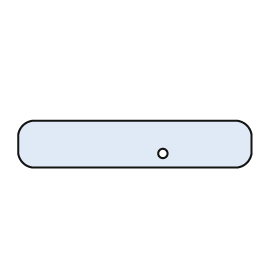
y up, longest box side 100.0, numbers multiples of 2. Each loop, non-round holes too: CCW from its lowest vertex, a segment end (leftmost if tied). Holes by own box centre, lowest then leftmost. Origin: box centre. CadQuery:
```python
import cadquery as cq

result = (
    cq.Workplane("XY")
    .moveTo(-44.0, -10.0)
    .lineTo(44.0, -10.0)
    .threePointArc((48.0, -8.0), (50.0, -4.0))
    .lineTo(50.0, 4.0)
    .threePointArc((48.0, 8.0), (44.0, 10.0))
    .lineTo(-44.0, 10.0)
    .threePointArc((-48.0, 8.0), (-50.0, 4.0))
    .lineTo(-50.0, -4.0)
    .threePointArc((-48.0, -8.0), (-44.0, -10.0))
    .close()
    .moveTo(12.0, -4.0)
    .circle(2.0)
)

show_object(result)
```